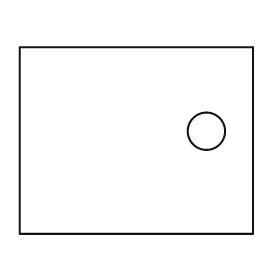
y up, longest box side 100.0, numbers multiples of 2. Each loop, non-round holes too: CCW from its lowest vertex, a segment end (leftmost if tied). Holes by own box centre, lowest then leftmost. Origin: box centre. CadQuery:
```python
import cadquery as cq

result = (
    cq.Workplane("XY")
    .moveTo(-50.0, -40.0)
    .lineTo(50.0, -40.0)
    .lineTo(50.0, 40.0)
    .lineTo(-50.0, 40.0)
    .close()
    .moveTo(30.0, 4.0)
    .circle(8.0)
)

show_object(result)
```